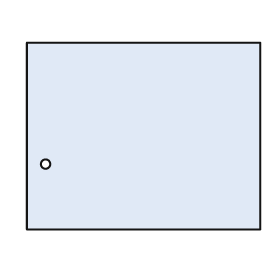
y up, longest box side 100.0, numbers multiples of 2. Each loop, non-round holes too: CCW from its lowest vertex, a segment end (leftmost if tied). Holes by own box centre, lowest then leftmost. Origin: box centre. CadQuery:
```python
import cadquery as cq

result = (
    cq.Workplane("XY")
    .moveTo(-50.0, -40.0)
    .lineTo(50.0, -40.0)
    .lineTo(50.0, 40.0)
    .lineTo(-50.0, 40.0)
    .close()
    .moveTo(-42.0, -12.0)
    .circle(2.0)
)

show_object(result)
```